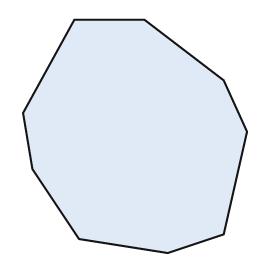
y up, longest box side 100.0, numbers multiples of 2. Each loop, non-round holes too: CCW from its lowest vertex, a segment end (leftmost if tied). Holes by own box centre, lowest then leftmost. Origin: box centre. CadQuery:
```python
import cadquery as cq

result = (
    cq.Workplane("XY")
    .moveTo(14.0, -50.0)
    .lineTo(38.0, -42.0)
    .lineTo(48.0, 2.0)
    .lineTo(38.0, 24.0)
    .lineTo(4.0, 50.0)
    .lineTo(-26.0, 50.0)
    .lineTo(-48.0, 10.0)
    .lineTo(-44.0, -14.0)
    .lineTo(-24.0, -44.0)
    .close()
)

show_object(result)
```